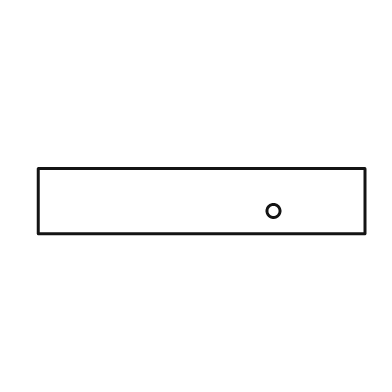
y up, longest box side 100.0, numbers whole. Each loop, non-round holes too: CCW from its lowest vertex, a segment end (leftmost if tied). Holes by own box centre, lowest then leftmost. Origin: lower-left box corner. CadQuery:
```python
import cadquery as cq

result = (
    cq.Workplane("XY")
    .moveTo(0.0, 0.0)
    .lineTo(100.0, 0.0)
    .lineTo(100.0, 20.0)
    .lineTo(0.0, 20.0)
    .close()
    .moveTo(72.0, 7.0)
    .circle(2.0)
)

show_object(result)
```